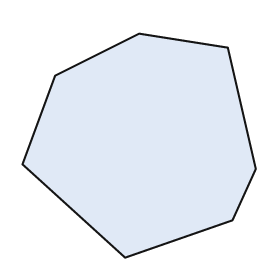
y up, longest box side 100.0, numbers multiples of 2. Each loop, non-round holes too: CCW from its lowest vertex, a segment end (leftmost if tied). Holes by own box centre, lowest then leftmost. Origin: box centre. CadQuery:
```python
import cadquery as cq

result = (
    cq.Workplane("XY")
    .moveTo(-6.0, -48.0)
    .lineTo(40.0, -32.0)
    .lineTo(50.0, -10.0)
    .lineTo(38.0, 42.0)
    .lineTo(0.0, 48.0)
    .lineTo(-36.0, 30.0)
    .lineTo(-50.0, -8.0)
    .close()
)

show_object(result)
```